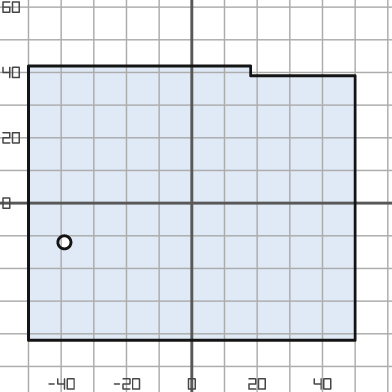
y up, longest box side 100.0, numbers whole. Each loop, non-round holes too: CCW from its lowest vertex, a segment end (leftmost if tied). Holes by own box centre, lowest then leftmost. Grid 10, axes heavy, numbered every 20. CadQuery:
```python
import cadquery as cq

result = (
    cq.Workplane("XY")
    .moveTo(-50.0, -42.0)
    .lineTo(50.0, -42.0)
    .lineTo(50.0, 39.0)
    .lineTo(18.0, 39.0)
    .lineTo(18.0, 42.0)
    .lineTo(-50.0, 42.0)
    .close()
    .moveTo(-39.0, -12.0)
    .circle(2.0)
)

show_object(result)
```